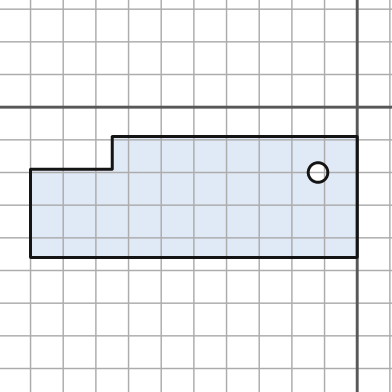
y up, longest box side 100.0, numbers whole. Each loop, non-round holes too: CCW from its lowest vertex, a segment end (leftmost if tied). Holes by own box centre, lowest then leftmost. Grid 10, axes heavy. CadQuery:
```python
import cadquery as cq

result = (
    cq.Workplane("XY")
    .moveTo(-100.0, -46.0)
    .lineTo(0.0, -46.0)
    .lineTo(0.0, -9.0)
    .lineTo(-75.0, -9.0)
    .lineTo(-75.0, -19.0)
    .lineTo(-100.0, -19.0)
    .close()
    .moveTo(-12.0, -20.0)
    .circle(3.0)
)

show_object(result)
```